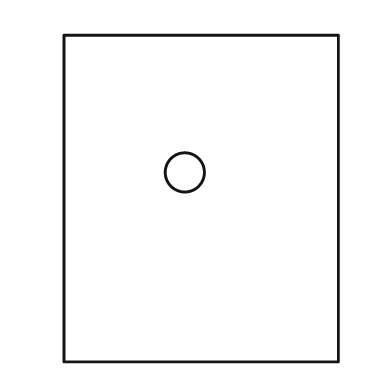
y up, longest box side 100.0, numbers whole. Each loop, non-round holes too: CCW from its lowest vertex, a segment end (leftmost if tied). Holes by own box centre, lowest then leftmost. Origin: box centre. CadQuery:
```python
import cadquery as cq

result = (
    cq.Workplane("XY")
    .moveTo(-42.0, -50.0)
    .lineTo(42.0, -50.0)
    .lineTo(42.0, 50.0)
    .lineTo(-42.0, 50.0)
    .close()
    .moveTo(-5.0, 8.0)
    .circle(6.0)
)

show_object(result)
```